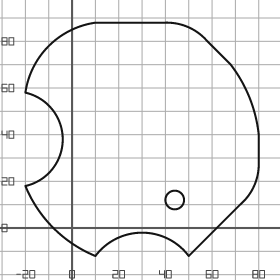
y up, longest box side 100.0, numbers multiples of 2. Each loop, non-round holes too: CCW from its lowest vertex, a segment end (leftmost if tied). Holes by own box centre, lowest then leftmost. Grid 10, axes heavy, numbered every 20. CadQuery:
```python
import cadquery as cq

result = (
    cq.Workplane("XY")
    .moveTo(10.0, -12.0)
    .threePointArc((30.0, -2.0), (50.0, -12.0))
    .lineTo(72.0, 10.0)
    .threePointArc((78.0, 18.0), (80.0, 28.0))
    .lineTo(80.0, 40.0)
    .threePointArc((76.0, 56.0), (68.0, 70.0))
    .lineTo(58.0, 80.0)
    .threePointArc((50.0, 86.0), (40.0, 88.0))
    .lineTo(10.0, 88.0)
    .threePointArc((-10.0, 78.0), (-20.0, 58.0))
    .threePointArc((-4.0, 38.0), (-20.0, 18.0))
    .threePointArc((-8.0, 0.0), (10.0, -12.0))
    .close()
    .moveTo(44.0, 12.0)
    .circle(4.0)
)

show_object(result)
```